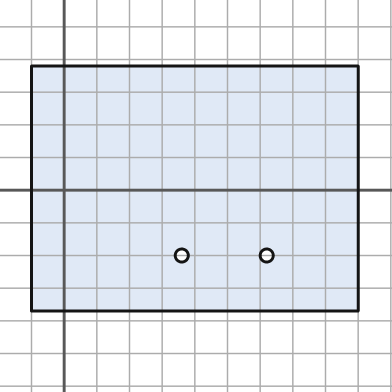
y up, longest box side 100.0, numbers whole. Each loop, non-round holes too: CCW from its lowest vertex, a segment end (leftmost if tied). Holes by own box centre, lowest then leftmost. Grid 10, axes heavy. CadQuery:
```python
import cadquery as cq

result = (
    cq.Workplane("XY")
    .moveTo(-10.0, -37.0)
    .lineTo(90.0, -37.0)
    .lineTo(90.0, 38.0)
    .lineTo(-10.0, 38.0)
    .close()
    .moveTo(36.0, -20.0)
    .circle(2.0)
    .moveTo(62.0, -20.0)
    .circle(2.0)
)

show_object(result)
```